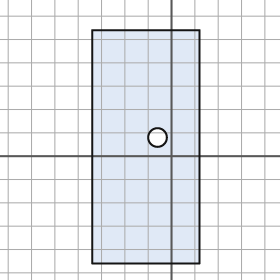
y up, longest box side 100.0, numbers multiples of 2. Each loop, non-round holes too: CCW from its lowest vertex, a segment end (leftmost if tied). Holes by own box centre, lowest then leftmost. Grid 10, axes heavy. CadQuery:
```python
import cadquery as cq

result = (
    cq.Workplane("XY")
    .moveTo(-34.0, -46.0)
    .lineTo(12.0, -46.0)
    .lineTo(12.0, 54.0)
    .lineTo(-34.0, 54.0)
    .close()
    .moveTo(-6.0, 8.0)
    .circle(4.0)
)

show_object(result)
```